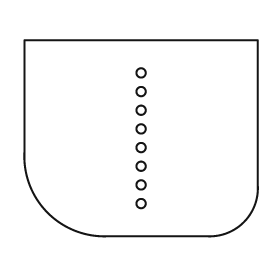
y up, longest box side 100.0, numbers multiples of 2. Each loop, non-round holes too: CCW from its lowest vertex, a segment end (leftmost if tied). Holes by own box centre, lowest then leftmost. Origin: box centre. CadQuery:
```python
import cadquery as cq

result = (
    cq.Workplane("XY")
    .moveTo(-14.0, -42.0)
    .lineTo(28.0, -42.0)
    .threePointArc((44.0, -36.0), (50.0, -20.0))
    .lineTo(50.0, 42.0)
    .lineTo(-50.0, 42.0)
    .lineTo(-50.0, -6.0)
    .threePointArc((-40.0, -32.0), (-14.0, -42.0))
    .close()
    .moveTo(0.0, -28.0)
    .circle(2.0)
    .moveTo(0.0, -20.0)
    .circle(2.0)
    .moveTo(0.0, -12.0)
    .circle(2.0)
    .moveTo(0.0, -4.0)
    .circle(2.0)
    .moveTo(0.0, 4.0)
    .circle(2.0)
    .moveTo(0.0, 12.0)
    .circle(2.0)
    .moveTo(0.0, 20.0)
    .circle(2.0)
    .moveTo(0.0, 28.0)
    .circle(2.0)
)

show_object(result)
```